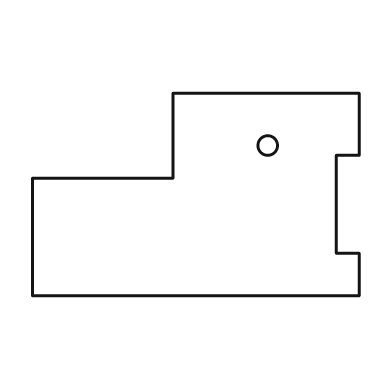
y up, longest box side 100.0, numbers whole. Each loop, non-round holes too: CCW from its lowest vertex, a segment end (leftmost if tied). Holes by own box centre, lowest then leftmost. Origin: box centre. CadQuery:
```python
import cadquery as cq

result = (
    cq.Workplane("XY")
    .moveTo(-50.0, -31.0)
    .lineTo(50.0, -31.0)
    .lineTo(50.0, -18.0)
    .lineTo(43.0, -18.0)
    .lineTo(43.0, 12.0)
    .lineTo(50.0, 12.0)
    .lineTo(50.0, 31.0)
    .lineTo(-7.0, 31.0)
    .lineTo(-7.0, 5.0)
    .lineTo(-50.0, 5.0)
    .close()
    .moveTo(22.0, 15.0)
    .circle(3.0)
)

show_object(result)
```